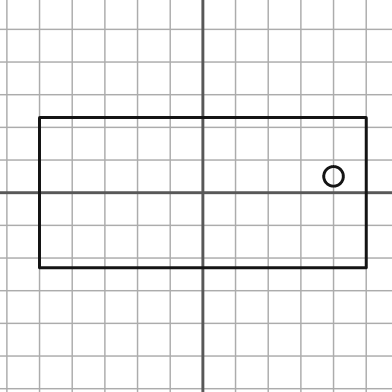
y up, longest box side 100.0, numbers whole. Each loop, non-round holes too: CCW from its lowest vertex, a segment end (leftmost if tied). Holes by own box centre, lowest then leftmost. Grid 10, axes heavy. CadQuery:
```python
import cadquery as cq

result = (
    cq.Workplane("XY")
    .moveTo(-50.0, -23.0)
    .lineTo(50.0, -23.0)
    .lineTo(50.0, 23.0)
    .lineTo(-50.0, 23.0)
    .close()
    .moveTo(40.0, 5.0)
    .circle(3.0)
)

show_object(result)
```